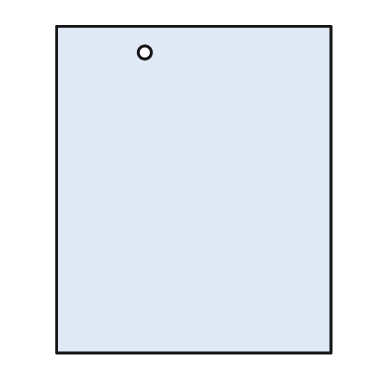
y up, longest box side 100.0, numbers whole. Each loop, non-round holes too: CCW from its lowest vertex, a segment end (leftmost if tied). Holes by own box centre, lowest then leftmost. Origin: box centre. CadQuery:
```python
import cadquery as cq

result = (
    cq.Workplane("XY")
    .moveTo(-42.0, -50.0)
    .lineTo(42.0, -50.0)
    .lineTo(42.0, 50.0)
    .lineTo(-42.0, 50.0)
    .close()
    .moveTo(-15.0, 42.0)
    .circle(2.0)
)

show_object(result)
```